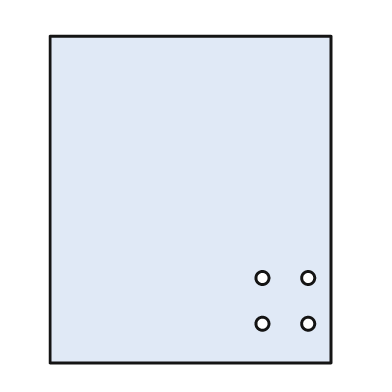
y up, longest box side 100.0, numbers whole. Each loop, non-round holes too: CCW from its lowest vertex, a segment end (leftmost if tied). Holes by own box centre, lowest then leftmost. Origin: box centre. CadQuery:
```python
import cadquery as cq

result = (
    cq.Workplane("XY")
    .moveTo(-43.0, -50.0)
    .lineTo(43.0, -50.0)
    .lineTo(43.0, 50.0)
    .lineTo(-43.0, 50.0)
    .close()
    .moveTo(22.0, -38.0)
    .circle(2.0)
    .moveTo(36.0, -38.0)
    .circle(2.0)
    .moveTo(22.0, -24.0)
    .circle(2.0)
    .moveTo(36.0, -24.0)
    .circle(2.0)
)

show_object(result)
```